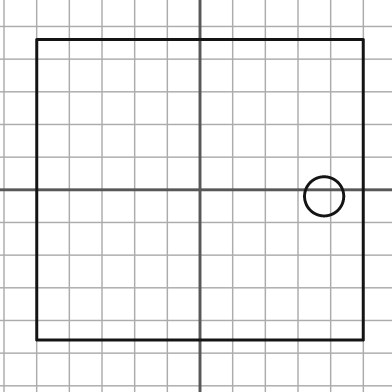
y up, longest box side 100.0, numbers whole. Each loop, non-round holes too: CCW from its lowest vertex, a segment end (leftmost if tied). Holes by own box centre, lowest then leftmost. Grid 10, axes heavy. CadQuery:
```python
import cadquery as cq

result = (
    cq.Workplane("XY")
    .moveTo(-50.0, -46.0)
    .lineTo(50.0, -46.0)
    .lineTo(50.0, 46.0)
    .lineTo(-50.0, 46.0)
    .close()
    .moveTo(38.0, -2.0)
    .circle(6.0)
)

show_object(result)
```